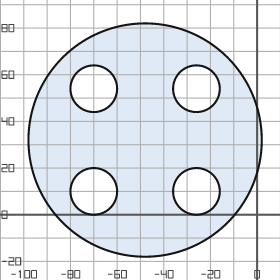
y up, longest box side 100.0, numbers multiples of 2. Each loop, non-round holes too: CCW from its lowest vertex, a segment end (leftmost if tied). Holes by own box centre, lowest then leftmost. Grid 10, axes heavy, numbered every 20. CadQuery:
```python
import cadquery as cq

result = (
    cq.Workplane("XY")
    .moveTo(-48.0, 32.0)
    .circle(50.0)
    .moveTo(-70.0, 10.0)
    .circle(10.0)
    .moveTo(-26.0, 10.0)
    .circle(10.0)
    .moveTo(-70.0, 54.0)
    .circle(10.0)
    .moveTo(-26.0, 54.0)
    .circle(10.0)
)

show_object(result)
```